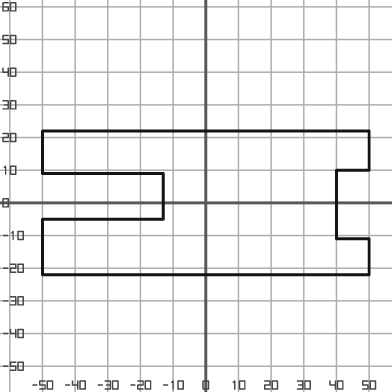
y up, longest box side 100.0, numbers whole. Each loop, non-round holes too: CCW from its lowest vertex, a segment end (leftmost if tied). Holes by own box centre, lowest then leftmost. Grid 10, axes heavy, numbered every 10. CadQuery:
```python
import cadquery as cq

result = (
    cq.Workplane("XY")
    .moveTo(-50.0, -22.0)
    .lineTo(50.0, -22.0)
    .lineTo(50.0, -11.0)
    .lineTo(40.0, -11.0)
    .lineTo(40.0, 10.0)
    .lineTo(50.0, 10.0)
    .lineTo(50.0, 22.0)
    .lineTo(-50.0, 22.0)
    .lineTo(-50.0, 9.0)
    .lineTo(-13.0, 9.0)
    .lineTo(-13.0, -5.0)
    .lineTo(-50.0, -5.0)
    .close()
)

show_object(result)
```